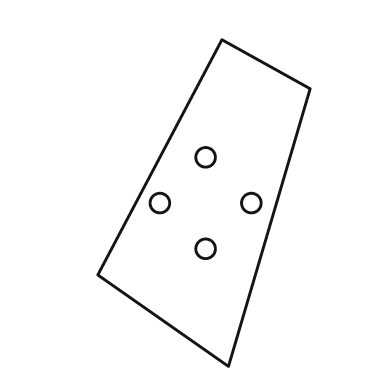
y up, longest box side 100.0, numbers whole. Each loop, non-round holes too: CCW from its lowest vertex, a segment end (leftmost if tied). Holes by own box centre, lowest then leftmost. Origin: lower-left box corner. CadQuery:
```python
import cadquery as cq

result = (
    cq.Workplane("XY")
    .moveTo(40.0, 0.0)
    .lineTo(65.0, 85.0)
    .lineTo(38.0, 100.0)
    .lineTo(0.0, 28.0)
    .close()
    .moveTo(33.0, 36.0)
    .circle(3.0)
    .moveTo(19.0, 50.0)
    .circle(3.0)
    .moveTo(47.0, 50.0)
    .circle(3.0)
    .moveTo(33.0, 64.0)
    .circle(3.0)
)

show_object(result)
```